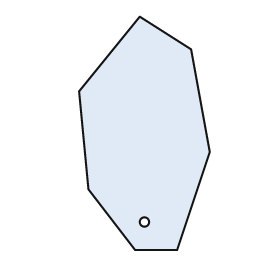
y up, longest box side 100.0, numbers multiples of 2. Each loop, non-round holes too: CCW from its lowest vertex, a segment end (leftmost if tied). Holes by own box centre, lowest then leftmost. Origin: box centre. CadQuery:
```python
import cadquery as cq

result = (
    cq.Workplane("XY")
    .moveTo(-4.0, -50.0)
    .lineTo(14.0, -50.0)
    .lineTo(28.0, -8.0)
    .lineTo(20.0, 36.0)
    .lineTo(-2.0, 50.0)
    .lineTo(-28.0, 18.0)
    .lineTo(-24.0, -24.0)
    .close()
    .moveTo(0.0, -38.0)
    .circle(2.0)
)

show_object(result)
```